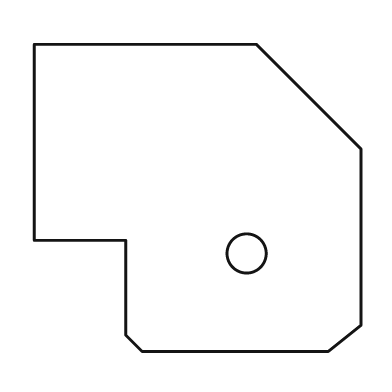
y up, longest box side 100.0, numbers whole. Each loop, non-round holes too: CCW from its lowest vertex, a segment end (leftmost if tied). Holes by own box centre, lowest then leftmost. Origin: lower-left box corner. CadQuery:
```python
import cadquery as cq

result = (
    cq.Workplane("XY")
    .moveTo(33.0, 0.0)
    .lineTo(90.0, 0.0)
    .lineTo(100.0, 8.0)
    .lineTo(100.0, 62.0)
    .lineTo(68.0, 94.0)
    .lineTo(0.0, 94.0)
    .lineTo(0.0, 34.0)
    .lineTo(28.0, 34.0)
    .lineTo(28.0, 5.0)
    .close()
    .moveTo(65.0, 30.0)
    .circle(6.0)
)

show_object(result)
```